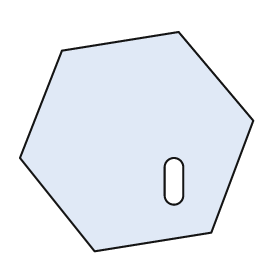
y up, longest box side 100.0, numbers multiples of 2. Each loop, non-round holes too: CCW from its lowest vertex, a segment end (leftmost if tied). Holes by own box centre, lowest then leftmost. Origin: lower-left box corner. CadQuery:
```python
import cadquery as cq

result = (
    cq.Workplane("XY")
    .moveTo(32.0, 0.0)
    .lineTo(82.0, 8.0)
    .lineTo(100.0, 56.0)
    .lineTo(68.0, 94.0)
    .lineTo(18.0, 86.0)
    .lineTo(0.0, 40.0)
    .close()
    .moveTo(62.0, 24.0)
    .threePointArc((66.0, 20.0), (70.0, 24.0))
    .lineTo(70.0, 36.0)
    .threePointArc((66.0, 40.0), (62.0, 36.0))
    .close()
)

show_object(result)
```